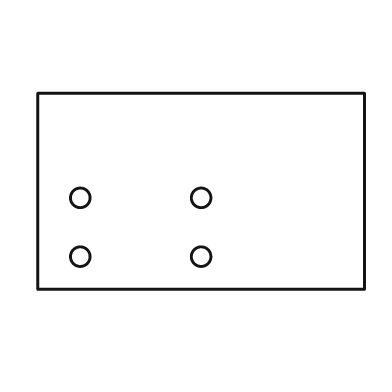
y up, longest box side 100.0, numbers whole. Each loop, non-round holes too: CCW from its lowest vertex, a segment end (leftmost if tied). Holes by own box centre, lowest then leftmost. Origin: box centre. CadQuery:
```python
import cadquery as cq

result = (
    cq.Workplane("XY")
    .moveTo(-50.0, -30.0)
    .lineTo(50.0, -30.0)
    .lineTo(50.0, 30.0)
    .lineTo(-50.0, 30.0)
    .close()
    .moveTo(-37.0, -20.0)
    .circle(3.0)
    .moveTo(0.0, -20.0)
    .circle(3.0)
    .moveTo(-37.0, -2.0)
    .circle(3.0)
    .moveTo(0.0, -2.0)
    .circle(3.0)
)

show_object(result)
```